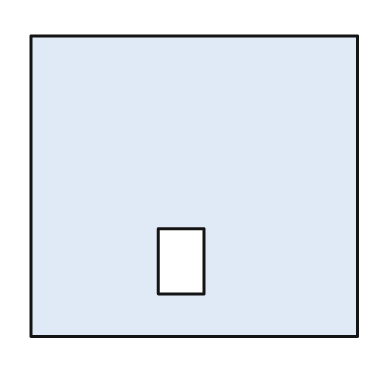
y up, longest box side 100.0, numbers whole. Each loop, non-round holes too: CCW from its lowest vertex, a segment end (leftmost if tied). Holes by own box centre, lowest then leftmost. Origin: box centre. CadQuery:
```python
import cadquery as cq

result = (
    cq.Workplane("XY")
    .moveTo(-50.0, -46.0)
    .lineTo(50.0, -46.0)
    .lineTo(50.0, 46.0)
    .lineTo(-50.0, 46.0)
    .close()
    .moveTo(-11.0, -33.0)
    .lineTo(3.0, -33.0)
    .lineTo(3.0, -13.0)
    .lineTo(-11.0, -13.0)
    .close()
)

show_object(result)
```